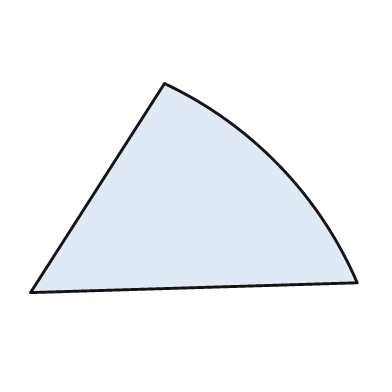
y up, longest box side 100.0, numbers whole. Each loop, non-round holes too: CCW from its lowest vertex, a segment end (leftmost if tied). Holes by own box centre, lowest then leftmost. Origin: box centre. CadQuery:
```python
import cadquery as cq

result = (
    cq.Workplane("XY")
    .moveTo(-50.0, -32.0)
    .lineTo(50.0, -29.0)
    .threePointArc((26.0, 7.0), (-9.0, 32.0))
    .close()
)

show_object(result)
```